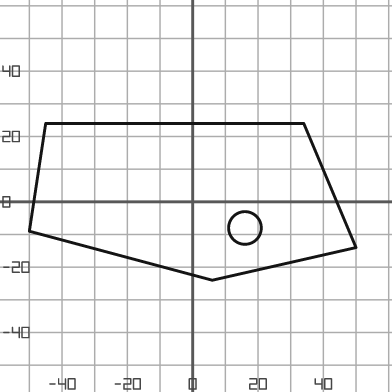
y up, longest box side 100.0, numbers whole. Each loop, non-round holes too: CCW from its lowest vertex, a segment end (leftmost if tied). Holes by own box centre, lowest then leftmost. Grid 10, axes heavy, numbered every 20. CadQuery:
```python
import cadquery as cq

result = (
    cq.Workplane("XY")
    .moveTo(6.0, -24.0)
    .lineTo(50.0, -14.0)
    .lineTo(34.0, 24.0)
    .lineTo(-45.0, 24.0)
    .lineTo(-50.0, -9.0)
    .close()
    .moveTo(16.0, -8.0)
    .circle(5.0)
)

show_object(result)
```